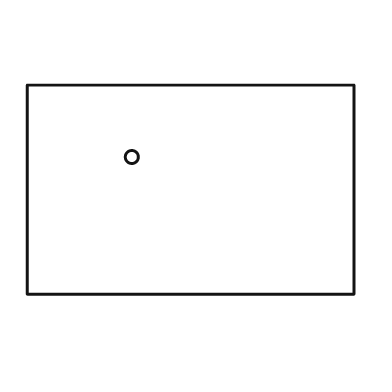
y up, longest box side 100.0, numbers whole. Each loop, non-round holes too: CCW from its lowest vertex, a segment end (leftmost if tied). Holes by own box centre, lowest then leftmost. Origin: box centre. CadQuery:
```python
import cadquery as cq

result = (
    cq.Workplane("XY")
    .moveTo(-50.0, -32.0)
    .lineTo(50.0, -32.0)
    .lineTo(50.0, 32.0)
    .lineTo(-50.0, 32.0)
    .close()
    .moveTo(-18.0, 10.0)
    .circle(2.0)
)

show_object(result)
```